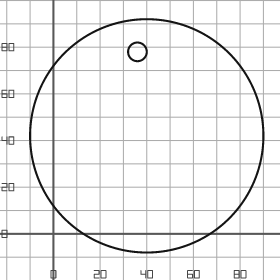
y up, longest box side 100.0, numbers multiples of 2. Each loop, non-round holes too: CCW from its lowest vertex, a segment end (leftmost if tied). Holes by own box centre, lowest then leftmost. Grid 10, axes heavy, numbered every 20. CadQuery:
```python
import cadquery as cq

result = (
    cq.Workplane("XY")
    .moveTo(40.0, 42.0)
    .circle(50.0)
    .moveTo(36.0, 78.0)
    .circle(4.0)
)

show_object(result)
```